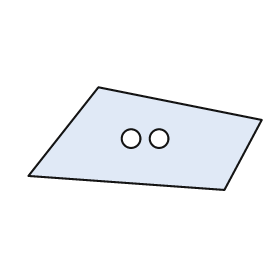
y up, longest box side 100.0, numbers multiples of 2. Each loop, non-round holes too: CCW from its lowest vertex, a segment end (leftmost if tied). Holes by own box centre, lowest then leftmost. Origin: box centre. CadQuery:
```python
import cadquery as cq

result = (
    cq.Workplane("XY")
    .moveTo(34.0, -22.0)
    .lineTo(50.0, 8.0)
    .lineTo(-20.0, 22.0)
    .lineTo(-50.0, -16.0)
    .close()
    .moveTo(-6.0, 0.0)
    .circle(4.0)
    .moveTo(6.0, 0.0)
    .circle(4.0)
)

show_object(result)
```